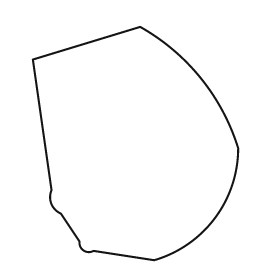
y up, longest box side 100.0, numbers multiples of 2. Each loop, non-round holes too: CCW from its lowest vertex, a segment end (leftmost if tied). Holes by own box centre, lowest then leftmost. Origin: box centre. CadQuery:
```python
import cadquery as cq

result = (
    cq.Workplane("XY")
    .moveTo(8.0, -50.0)
    .threePointArc((34.0, -32.0), (44.0, -2.0))
    .threePointArc((28.0, 28.0), (2.0, 50.0))
    .lineTo(-44.0, 36.0)
    .lineTo(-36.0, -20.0)
    .threePointArc((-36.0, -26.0), (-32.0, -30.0))
    .lineTo(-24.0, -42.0)
    .threePointArc((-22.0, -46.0), (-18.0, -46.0))
    .close()
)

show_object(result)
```